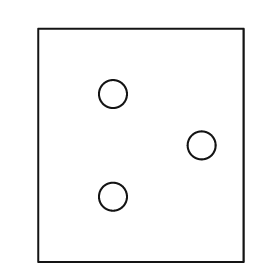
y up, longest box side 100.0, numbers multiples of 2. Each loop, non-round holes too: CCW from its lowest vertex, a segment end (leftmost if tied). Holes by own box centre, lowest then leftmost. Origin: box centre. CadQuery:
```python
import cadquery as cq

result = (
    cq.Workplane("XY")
    .moveTo(-44.0, -50.0)
    .lineTo(44.0, -50.0)
    .lineTo(44.0, 50.0)
    .lineTo(-44.0, 50.0)
    .close()
    .moveTo(-12.0, -22.0)
    .circle(6.0)
    .moveTo(26.0, 0.0)
    .circle(6.0)
    .moveTo(-12.0, 22.0)
    .circle(6.0)
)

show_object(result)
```